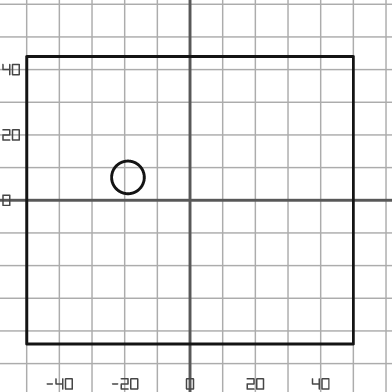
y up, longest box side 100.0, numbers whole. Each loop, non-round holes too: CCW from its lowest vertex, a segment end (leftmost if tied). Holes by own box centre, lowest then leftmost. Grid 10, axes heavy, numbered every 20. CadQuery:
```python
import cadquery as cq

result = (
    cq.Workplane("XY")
    .moveTo(-50.0, -44.0)
    .lineTo(50.0, -44.0)
    .lineTo(50.0, 44.0)
    .lineTo(-50.0, 44.0)
    .close()
    .moveTo(-19.0, 7.0)
    .circle(5.0)
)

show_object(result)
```